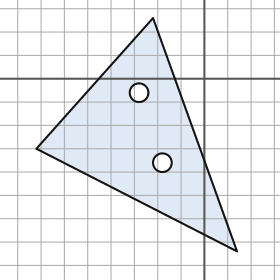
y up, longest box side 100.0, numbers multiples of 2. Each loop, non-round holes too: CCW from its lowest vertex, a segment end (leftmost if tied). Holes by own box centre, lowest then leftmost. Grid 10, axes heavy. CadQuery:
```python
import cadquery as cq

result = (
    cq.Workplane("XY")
    .moveTo(14.0, -74.0)
    .lineTo(-22.0, 26.0)
    .lineTo(-72.0, -30.0)
    .close()
    .moveTo(-18.0, -36.0)
    .circle(4.0)
    .moveTo(-28.0, -6.0)
    .circle(4.0)
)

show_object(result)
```